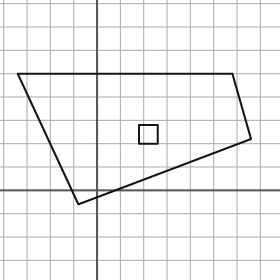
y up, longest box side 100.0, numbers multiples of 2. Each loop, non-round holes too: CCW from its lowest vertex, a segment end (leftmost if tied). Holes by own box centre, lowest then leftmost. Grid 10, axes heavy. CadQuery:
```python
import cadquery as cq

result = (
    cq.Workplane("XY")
    .moveTo(-8.0, -6.0)
    .lineTo(66.0, 22.0)
    .lineTo(58.0, 50.0)
    .lineTo(-34.0, 50.0)
    .close()
    .moveTo(18.0, 20.0)
    .lineTo(26.0, 20.0)
    .lineTo(26.0, 28.0)
    .lineTo(18.0, 28.0)
    .close()
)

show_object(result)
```